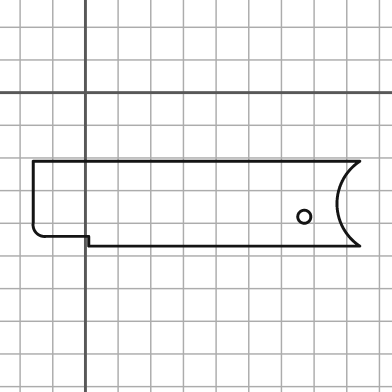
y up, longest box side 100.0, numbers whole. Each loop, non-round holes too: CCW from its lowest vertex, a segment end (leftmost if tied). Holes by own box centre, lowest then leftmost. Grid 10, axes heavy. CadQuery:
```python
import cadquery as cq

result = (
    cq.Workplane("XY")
    .moveTo(1.0, -47.0)
    .lineTo(84.0, -47.0)
    .threePointArc((77.0, -34.0), (84.0, -21.0))
    .lineTo(-16.0, -21.0)
    .lineTo(-16.0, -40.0)
    .threePointArc((-15.0, -43.0), (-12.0, -44.0))
    .lineTo(1.0, -44.0)
    .close()
    .moveTo(67.0, -38.0)
    .circle(2.0)
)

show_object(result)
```